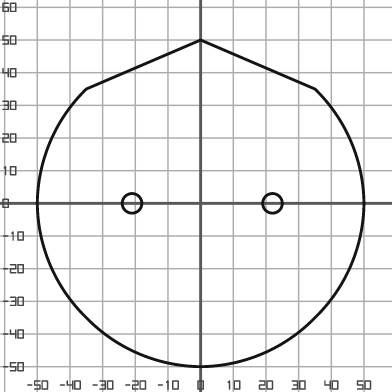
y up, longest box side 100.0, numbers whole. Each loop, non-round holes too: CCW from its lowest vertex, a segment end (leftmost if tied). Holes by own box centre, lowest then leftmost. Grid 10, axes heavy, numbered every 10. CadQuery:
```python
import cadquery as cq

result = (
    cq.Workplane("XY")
    .moveTo(0.0, -50.0)
    .threePointArc((19.0, -46.0), (35.0, -35.0))
    .threePointArc((46.0, -19.0), (50.0, 0.0))
    .threePointArc((46.0, 19.0), (35.0, 35.0))
    .lineTo(0.0, 50.0)
    .lineTo(-35.0, 35.0)
    .threePointArc((-46.0, 19.0), (-50.0, 0.0))
    .threePointArc((-46.0, -19.0), (-35.0, -35.0))
    .threePointArc((-19.0, -46.0), (0.0, -50.0))
    .close()
    .moveTo(-21.0, 0.0)
    .circle(3.0)
    .moveTo(22.0, 0.0)
    .circle(3.0)
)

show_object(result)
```